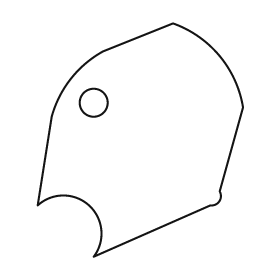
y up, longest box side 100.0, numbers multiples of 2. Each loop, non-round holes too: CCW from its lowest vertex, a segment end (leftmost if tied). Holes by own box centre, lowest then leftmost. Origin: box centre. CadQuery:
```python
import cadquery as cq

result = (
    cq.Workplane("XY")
    .moveTo(-20.0, -50.0)
    .lineTo(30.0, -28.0)
    .threePointArc((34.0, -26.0), (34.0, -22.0))
    .lineTo(44.0, 14.0)
    .threePointArc((34.0, 36.0), (14.0, 50.0))
    .lineTo(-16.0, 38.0)
    .threePointArc((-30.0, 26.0), (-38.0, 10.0))
    .lineTo(-44.0, -28.0)
    .threePointArc((-22.0, -28.0), (-20.0, -50.0))
    .close()
    .moveTo(-20.0, 16.0)
    .circle(6.0)
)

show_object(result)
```